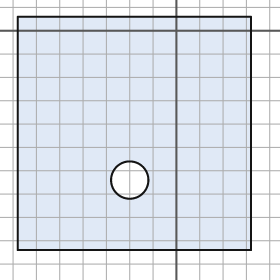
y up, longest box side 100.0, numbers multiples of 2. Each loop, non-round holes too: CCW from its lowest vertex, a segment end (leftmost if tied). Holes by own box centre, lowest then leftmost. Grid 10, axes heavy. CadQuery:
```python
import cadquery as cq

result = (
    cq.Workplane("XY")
    .moveTo(-68.0, -94.0)
    .lineTo(32.0, -94.0)
    .lineTo(32.0, 6.0)
    .lineTo(-68.0, 6.0)
    .close()
    .moveTo(-20.0, -64.0)
    .circle(8.0)
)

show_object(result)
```